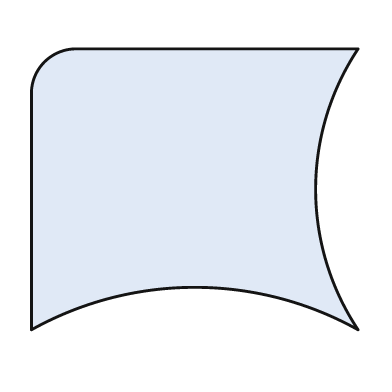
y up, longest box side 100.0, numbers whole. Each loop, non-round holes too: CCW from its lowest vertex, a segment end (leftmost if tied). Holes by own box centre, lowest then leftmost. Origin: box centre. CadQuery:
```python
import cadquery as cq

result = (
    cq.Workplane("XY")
    .moveTo(-50.0, -43.0)
    .threePointArc((0.0, -30.0), (50.0, -43.0))
    .threePointArc((37.0, 0.0), (50.0, 43.0))
    .lineTo(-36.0, 43.0)
    .threePointArc((-46.0, 39.0), (-50.0, 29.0))
    .close()
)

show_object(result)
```